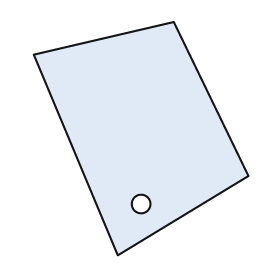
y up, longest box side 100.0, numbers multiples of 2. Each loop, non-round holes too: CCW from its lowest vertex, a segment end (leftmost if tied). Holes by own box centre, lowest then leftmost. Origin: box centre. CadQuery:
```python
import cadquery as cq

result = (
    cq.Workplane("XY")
    .moveTo(-10.0, -50.0)
    .lineTo(46.0, -16.0)
    .lineTo(14.0, 50.0)
    .lineTo(-46.0, 36.0)
    .close()
    .moveTo(0.0, -28.0)
    .circle(4.0)
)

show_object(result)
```